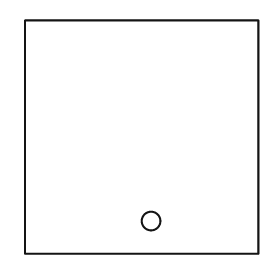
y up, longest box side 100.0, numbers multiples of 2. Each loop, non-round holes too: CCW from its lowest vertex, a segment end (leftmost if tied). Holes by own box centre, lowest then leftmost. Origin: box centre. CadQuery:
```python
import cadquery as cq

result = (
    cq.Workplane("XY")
    .moveTo(-50.0, -50.0)
    .lineTo(50.0, -50.0)
    .lineTo(50.0, 50.0)
    .lineTo(-50.0, 50.0)
    .close()
    .moveTo(4.0, -36.0)
    .circle(4.0)
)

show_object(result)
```